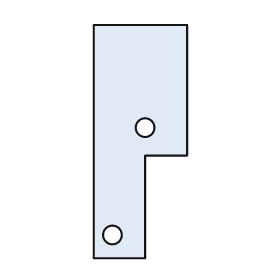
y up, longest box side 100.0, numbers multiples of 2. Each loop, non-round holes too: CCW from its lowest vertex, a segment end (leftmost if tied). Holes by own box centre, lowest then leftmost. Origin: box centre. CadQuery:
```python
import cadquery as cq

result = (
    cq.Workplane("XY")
    .moveTo(-20.0, -50.0)
    .lineTo(2.0, -50.0)
    .lineTo(2.0, -6.0)
    .lineTo(20.0, -6.0)
    .lineTo(20.0, 50.0)
    .lineTo(-20.0, 50.0)
    .close()
    .moveTo(-12.0, -40.0)
    .circle(4.0)
    .moveTo(2.0, 6.0)
    .circle(4.0)
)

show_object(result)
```